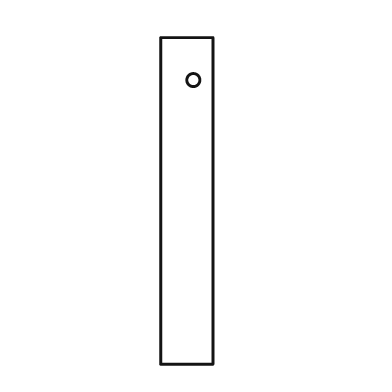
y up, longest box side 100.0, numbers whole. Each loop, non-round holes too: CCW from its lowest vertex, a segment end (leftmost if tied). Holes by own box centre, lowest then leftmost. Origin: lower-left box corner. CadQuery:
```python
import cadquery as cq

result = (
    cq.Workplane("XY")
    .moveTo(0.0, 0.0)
    .lineTo(16.0, 0.0)
    .lineTo(16.0, 100.0)
    .lineTo(0.0, 100.0)
    .close()
    .moveTo(10.0, 87.0)
    .circle(2.0)
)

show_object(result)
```